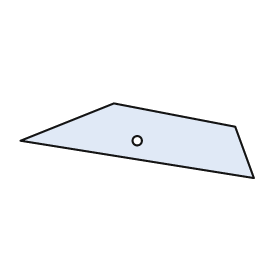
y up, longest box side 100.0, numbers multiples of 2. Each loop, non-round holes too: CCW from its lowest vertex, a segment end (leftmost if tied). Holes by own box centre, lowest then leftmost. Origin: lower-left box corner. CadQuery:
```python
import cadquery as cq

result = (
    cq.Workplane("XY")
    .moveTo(100.0, 0.0)
    .lineTo(92.0, 22.0)
    .lineTo(40.0, 32.0)
    .lineTo(0.0, 16.0)
    .close()
    .moveTo(50.0, 16.0)
    .circle(2.0)
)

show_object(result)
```